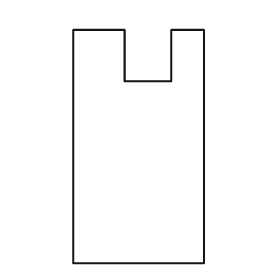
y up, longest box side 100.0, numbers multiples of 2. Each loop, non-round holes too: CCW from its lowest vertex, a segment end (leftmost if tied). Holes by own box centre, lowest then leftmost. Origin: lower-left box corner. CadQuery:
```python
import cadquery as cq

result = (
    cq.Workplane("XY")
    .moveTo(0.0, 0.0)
    .lineTo(56.0, 0.0)
    .lineTo(56.0, 100.0)
    .lineTo(42.0, 100.0)
    .lineTo(42.0, 78.0)
    .lineTo(22.0, 78.0)
    .lineTo(22.0, 100.0)
    .lineTo(0.0, 100.0)
    .close()
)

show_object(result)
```